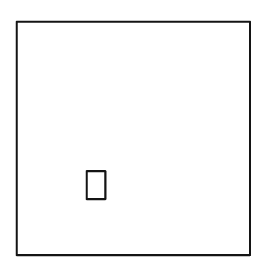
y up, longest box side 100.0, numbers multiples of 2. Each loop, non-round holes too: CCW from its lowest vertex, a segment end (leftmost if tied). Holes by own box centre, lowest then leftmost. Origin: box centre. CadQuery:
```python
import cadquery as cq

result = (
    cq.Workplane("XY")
    .moveTo(-50.0, -50.0)
    .lineTo(50.0, -50.0)
    .lineTo(50.0, 50.0)
    .lineTo(-50.0, 50.0)
    .close()
    .moveTo(-20.0, -26.0)
    .lineTo(-12.0, -26.0)
    .lineTo(-12.0, -14.0)
    .lineTo(-20.0, -14.0)
    .close()
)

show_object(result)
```